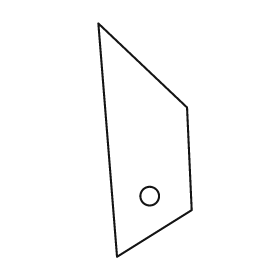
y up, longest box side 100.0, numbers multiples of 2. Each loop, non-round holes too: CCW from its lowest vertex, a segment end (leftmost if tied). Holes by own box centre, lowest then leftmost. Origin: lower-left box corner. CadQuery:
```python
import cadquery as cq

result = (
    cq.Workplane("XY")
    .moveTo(8.0, 0.0)
    .lineTo(40.0, 20.0)
    .lineTo(38.0, 64.0)
    .lineTo(0.0, 100.0)
    .close()
    .moveTo(22.0, 26.0)
    .circle(4.0)
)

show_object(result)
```